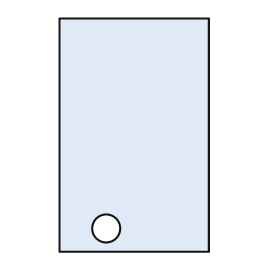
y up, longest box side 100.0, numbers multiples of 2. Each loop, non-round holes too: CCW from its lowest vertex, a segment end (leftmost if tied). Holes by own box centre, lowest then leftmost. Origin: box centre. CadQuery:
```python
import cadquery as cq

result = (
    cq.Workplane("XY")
    .moveTo(-32.0, -50.0)
    .lineTo(32.0, -50.0)
    .lineTo(32.0, 50.0)
    .lineTo(-32.0, 50.0)
    .close()
    .moveTo(-12.0, -40.0)
    .circle(6.0)
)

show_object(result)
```